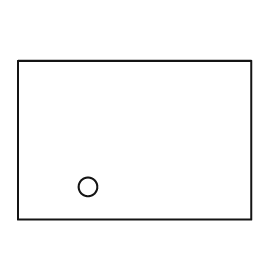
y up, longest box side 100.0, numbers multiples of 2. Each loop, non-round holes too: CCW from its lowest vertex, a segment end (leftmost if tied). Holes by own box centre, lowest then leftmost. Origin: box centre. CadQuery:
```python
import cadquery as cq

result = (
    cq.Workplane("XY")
    .moveTo(-50.0, -34.0)
    .lineTo(50.0, -34.0)
    .lineTo(50.0, 34.0)
    .lineTo(-50.0, 34.0)
    .close()
    .moveTo(-20.0, -20.0)
    .circle(4.0)
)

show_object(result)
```